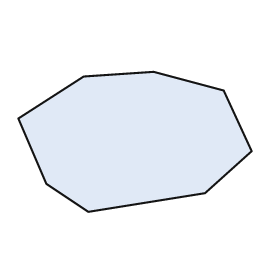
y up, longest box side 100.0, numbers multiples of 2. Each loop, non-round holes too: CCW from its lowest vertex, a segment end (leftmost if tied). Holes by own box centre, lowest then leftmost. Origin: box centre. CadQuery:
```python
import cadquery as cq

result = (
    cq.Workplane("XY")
    .moveTo(-20.0, -30.0)
    .lineTo(30.0, -22.0)
    .lineTo(50.0, -4.0)
    .lineTo(38.0, 22.0)
    .lineTo(8.0, 30.0)
    .lineTo(-22.0, 28.0)
    .lineTo(-50.0, 10.0)
    .lineTo(-38.0, -18.0)
    .close()
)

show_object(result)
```